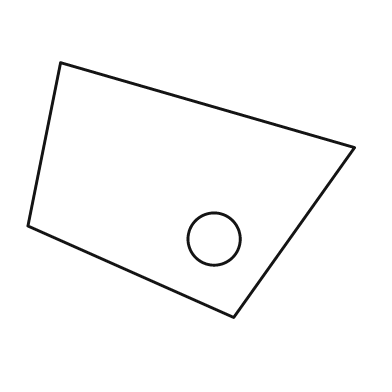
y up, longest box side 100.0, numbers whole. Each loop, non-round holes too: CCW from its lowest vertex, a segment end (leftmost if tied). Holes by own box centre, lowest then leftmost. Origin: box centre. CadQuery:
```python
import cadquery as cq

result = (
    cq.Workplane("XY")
    .moveTo(13.0, -39.0)
    .lineTo(50.0, 13.0)
    .lineTo(-40.0, 39.0)
    .lineTo(-50.0, -11.0)
    .close()
    .moveTo(7.0, -15.0)
    .circle(8.0)
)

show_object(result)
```